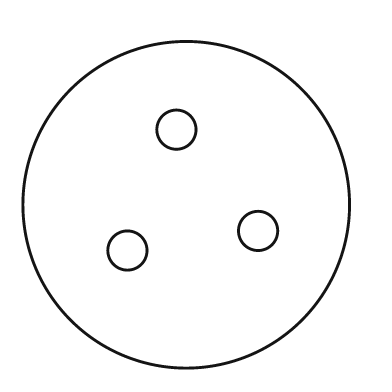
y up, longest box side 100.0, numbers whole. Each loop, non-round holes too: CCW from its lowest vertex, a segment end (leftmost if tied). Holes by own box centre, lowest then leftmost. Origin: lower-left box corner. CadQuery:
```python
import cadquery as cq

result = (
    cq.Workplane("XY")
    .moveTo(50.0, 50.0)
    .circle(50.0)
    .moveTo(32.0, 36.0)
    .circle(6.0)
    .moveTo(72.0, 42.0)
    .circle(6.0)
    .moveTo(47.0, 73.0)
    .circle(6.0)
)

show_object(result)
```